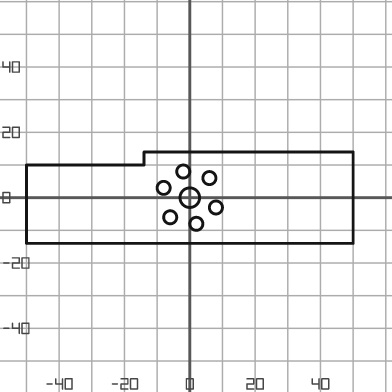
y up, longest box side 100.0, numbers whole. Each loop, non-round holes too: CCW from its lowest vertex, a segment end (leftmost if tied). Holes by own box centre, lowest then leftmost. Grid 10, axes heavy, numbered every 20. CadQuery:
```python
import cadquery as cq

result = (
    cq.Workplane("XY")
    .moveTo(-50.0, -14.0)
    .lineTo(50.0, -14.0)
    .lineTo(50.0, 14.0)
    .lineTo(-14.0, 14.0)
    .lineTo(-14.0, 10.0)
    .lineTo(-50.0, 10.0)
    .close()
    .moveTo(2.0, -8.0)
    .circle(2.0)
    .moveTo(-6.0, -6.0)
    .circle(2.0)
    .moveTo(8.0, -3.0)
    .circle(2.0)
    .moveTo(0.0, 0.0)
    .circle(3.0)
    .moveTo(-8.0, 3.0)
    .circle(2.0)
    .moveTo(6.0, 6.0)
    .circle(2.0)
    .moveTo(-2.0, 8.0)
    .circle(2.0)
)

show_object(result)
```